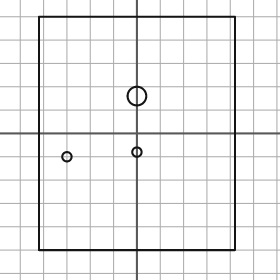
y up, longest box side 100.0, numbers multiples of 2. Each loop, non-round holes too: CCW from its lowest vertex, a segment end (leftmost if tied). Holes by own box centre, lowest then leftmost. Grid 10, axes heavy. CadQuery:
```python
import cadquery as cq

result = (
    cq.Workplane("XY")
    .moveTo(-42.0, -50.0)
    .lineTo(42.0, -50.0)
    .lineTo(42.0, 50.0)
    .lineTo(-42.0, 50.0)
    .close()
    .moveTo(-30.0, -10.0)
    .circle(2.0)
    .moveTo(0.0, -8.0)
    .circle(2.0)
    .moveTo(0.0, 16.0)
    .circle(4.0)
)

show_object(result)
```